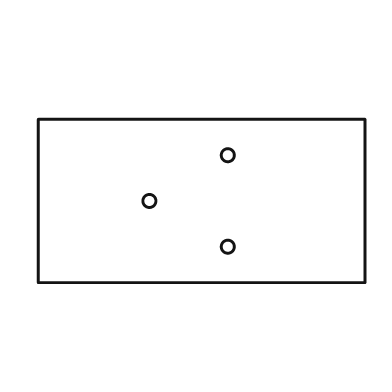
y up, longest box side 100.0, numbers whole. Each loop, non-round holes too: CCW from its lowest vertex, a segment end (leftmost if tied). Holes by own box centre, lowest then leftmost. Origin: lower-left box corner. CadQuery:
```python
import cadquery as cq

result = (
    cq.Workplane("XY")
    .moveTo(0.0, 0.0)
    .lineTo(100.0, 0.0)
    .lineTo(100.0, 50.0)
    .lineTo(0.0, 50.0)
    .close()
    .moveTo(58.0, 11.0)
    .circle(2.0)
    .moveTo(34.0, 25.0)
    .circle(2.0)
    .moveTo(58.0, 39.0)
    .circle(2.0)
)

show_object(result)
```